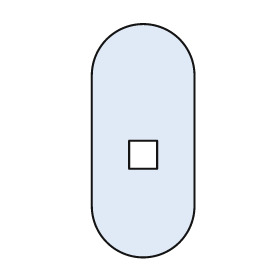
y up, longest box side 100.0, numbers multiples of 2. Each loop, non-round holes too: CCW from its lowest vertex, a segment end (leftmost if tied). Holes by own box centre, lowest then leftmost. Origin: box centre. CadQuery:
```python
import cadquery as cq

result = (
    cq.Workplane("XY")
    .moveTo(-22.0, -28.0)
    .threePointArc((0.0, -50.0), (22.0, -28.0))
    .lineTo(22.0, 28.0)
    .threePointArc((0.0, 50.0), (-22.0, 28.0))
    .close()
    .moveTo(-6.0, -12.0)
    .lineTo(6.0, -12.0)
    .lineTo(6.0, 0.0)
    .lineTo(-6.0, 0.0)
    .close()
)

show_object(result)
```